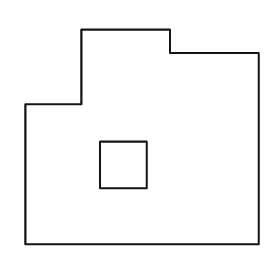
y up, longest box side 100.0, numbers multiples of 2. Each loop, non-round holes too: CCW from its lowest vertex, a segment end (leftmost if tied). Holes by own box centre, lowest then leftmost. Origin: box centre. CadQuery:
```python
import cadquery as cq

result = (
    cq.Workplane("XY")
    .moveTo(-50.0, -46.0)
    .lineTo(50.0, -46.0)
    .lineTo(50.0, 36.0)
    .lineTo(12.0, 36.0)
    .lineTo(12.0, 46.0)
    .lineTo(-26.0, 46.0)
    .lineTo(-26.0, 14.0)
    .lineTo(-50.0, 14.0)
    .close()
    .moveTo(-18.0, -22.0)
    .lineTo(2.0, -22.0)
    .lineTo(2.0, -2.0)
    .lineTo(-18.0, -2.0)
    .close()
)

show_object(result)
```